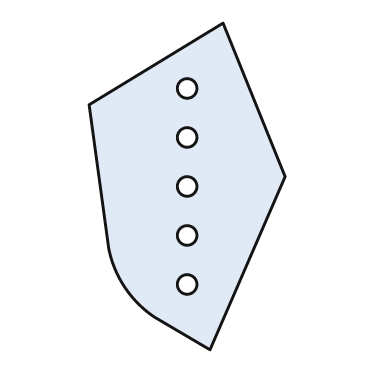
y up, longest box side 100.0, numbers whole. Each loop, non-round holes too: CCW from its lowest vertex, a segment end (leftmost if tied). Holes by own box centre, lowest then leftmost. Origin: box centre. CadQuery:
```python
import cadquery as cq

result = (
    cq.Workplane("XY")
    .moveTo(7.0, -50.0)
    .lineTo(30.0, 3.0)
    .lineTo(11.0, 50.0)
    .lineTo(-30.0, 25.0)
    .lineTo(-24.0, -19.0)
    .threePointArc((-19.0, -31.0), (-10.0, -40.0))
    .close()
    .moveTo(0.0, -30.0)
    .circle(3.0)
    .moveTo(0.0, -15.0)
    .circle(3.0)
    .moveTo(0.0, 0.0)
    .circle(3.0)
    .moveTo(0.0, 15.0)
    .circle(3.0)
    .moveTo(0.0, 30.0)
    .circle(3.0)
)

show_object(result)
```